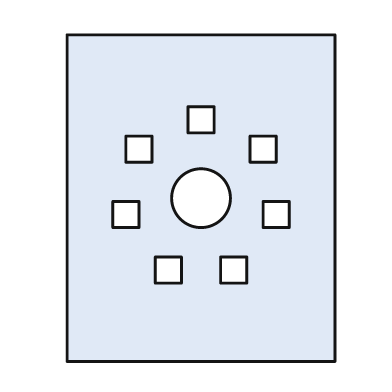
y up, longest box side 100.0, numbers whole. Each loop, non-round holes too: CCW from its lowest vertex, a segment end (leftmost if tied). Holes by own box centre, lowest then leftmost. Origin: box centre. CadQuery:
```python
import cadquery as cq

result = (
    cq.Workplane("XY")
    .moveTo(-41.0, -50.0)
    .lineTo(41.0, -50.0)
    .lineTo(41.0, 50.0)
    .lineTo(-41.0, 50.0)
    .close()
    .moveTo(-14.0, -26.0)
    .lineTo(-6.0, -26.0)
    .lineTo(-6.0, -18.0)
    .lineTo(-14.0, -18.0)
    .close()
    .moveTo(6.0, -26.0)
    .lineTo(14.0, -26.0)
    .lineTo(14.0, -18.0)
    .lineTo(6.0, -18.0)
    .close()
    .moveTo(-27.0, -9.0)
    .lineTo(-19.0, -9.0)
    .lineTo(-19.0, -1.0)
    .lineTo(-27.0, -1.0)
    .close()
    .moveTo(19.0, -9.0)
    .lineTo(27.0, -9.0)
    .lineTo(27.0, -1.0)
    .lineTo(19.0, -1.0)
    .close()
    .moveTo(0.0, 0.0)
    .circle(9.0)
    .moveTo(-23.0, 11.0)
    .lineTo(-15.0, 11.0)
    .lineTo(-15.0, 19.0)
    .lineTo(-23.0, 19.0)
    .close()
    .moveTo(15.0, 11.0)
    .lineTo(23.0, 11.0)
    .lineTo(23.0, 19.0)
    .lineTo(15.0, 19.0)
    .close()
    .moveTo(-4.0, 20.0)
    .lineTo(4.0, 20.0)
    .lineTo(4.0, 28.0)
    .lineTo(-4.0, 28.0)
    .close()
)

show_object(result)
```